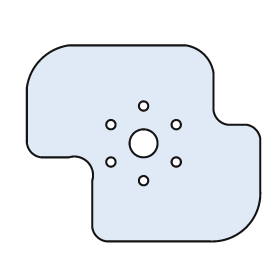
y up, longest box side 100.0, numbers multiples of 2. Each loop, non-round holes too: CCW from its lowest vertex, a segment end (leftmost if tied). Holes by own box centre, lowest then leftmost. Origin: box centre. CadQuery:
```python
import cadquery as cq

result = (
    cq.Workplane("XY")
    .moveTo(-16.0, -42.0)
    .lineTo(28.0, -42.0)
    .threePointArc((44.0, -36.0), (50.0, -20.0))
    .lineTo(50.0, 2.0)
    .threePointArc((48.0, 6.0), (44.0, 8.0))
    .lineTo(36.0, 8.0)
    .threePointArc((32.0, 10.0), (30.0, 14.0))
    .lineTo(30.0, 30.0)
    .threePointArc((26.0, 38.0), (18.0, 42.0))
    .lineTo(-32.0, 42.0)
    .threePointArc((-44.0, 36.0), (-50.0, 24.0))
    .lineTo(-50.0, 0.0)
    .threePointArc((-48.0, -4.0), (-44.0, -6.0))
    .lineTo(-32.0, -6.0)
    .threePointArc((-24.0, -8.0), (-22.0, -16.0))
    .lineTo(-22.0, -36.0)
    .threePointArc((-20.0, -40.0), (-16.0, -42.0))
    .close()
    .moveTo(0.0, -16.0)
    .circle(2.0)
    .moveTo(-14.0, -8.0)
    .circle(2.0)
    .moveTo(14.0, -8.0)
    .circle(2.0)
    .moveTo(0.0, 0.0)
    .circle(6.0)
    .moveTo(-14.0, 8.0)
    .circle(2.0)
    .moveTo(14.0, 8.0)
    .circle(2.0)
    .moveTo(0.0, 16.0)
    .circle(2.0)
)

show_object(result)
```